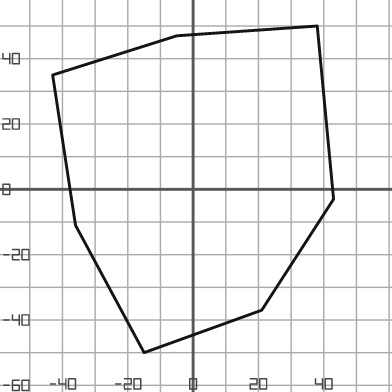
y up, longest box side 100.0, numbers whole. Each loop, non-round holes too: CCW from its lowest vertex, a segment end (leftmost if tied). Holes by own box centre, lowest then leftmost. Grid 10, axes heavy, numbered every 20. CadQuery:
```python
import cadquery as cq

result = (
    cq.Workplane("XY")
    .moveTo(-15.0, -50.0)
    .lineTo(21.0, -37.0)
    .lineTo(43.0, -3.0)
    .lineTo(38.0, 50.0)
    .lineTo(-5.0, 47.0)
    .lineTo(-43.0, 35.0)
    .lineTo(-36.0, -11.0)
    .close()
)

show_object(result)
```